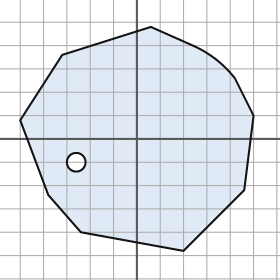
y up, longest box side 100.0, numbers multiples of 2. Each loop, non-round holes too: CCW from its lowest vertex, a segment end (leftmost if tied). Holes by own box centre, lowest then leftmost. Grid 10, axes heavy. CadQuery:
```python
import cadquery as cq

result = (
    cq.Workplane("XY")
    .moveTo(20.0, -48.0)
    .lineTo(46.0, -22.0)
    .lineTo(50.0, 10.0)
    .lineTo(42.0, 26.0)
    .threePointArc((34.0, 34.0), (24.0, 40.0))
    .lineTo(6.0, 48.0)
    .lineTo(-32.0, 36.0)
    .lineTo(-50.0, 8.0)
    .lineTo(-38.0, -24.0)
    .lineTo(-24.0, -40.0)
    .close()
    .moveTo(-26.0, -10.0)
    .circle(4.0)
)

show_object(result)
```